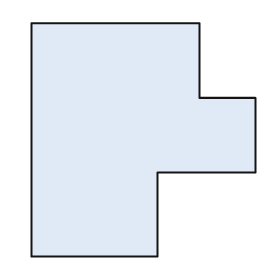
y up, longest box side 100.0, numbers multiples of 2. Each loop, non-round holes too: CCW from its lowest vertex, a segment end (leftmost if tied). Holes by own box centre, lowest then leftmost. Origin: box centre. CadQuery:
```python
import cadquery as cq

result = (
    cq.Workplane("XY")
    .moveTo(-48.0, -50.0)
    .lineTo(6.0, -50.0)
    .lineTo(6.0, -14.0)
    .lineTo(48.0, -14.0)
    .lineTo(48.0, 18.0)
    .lineTo(24.0, 18.0)
    .lineTo(24.0, 50.0)
    .lineTo(-48.0, 50.0)
    .close()
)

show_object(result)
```